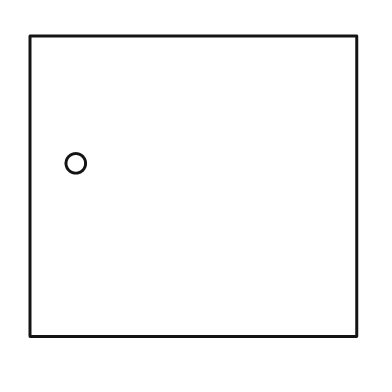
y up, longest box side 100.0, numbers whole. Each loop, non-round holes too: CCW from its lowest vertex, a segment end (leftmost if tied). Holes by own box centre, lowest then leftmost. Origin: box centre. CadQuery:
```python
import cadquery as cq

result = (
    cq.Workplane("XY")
    .moveTo(-50.0, -46.0)
    .lineTo(50.0, -46.0)
    .lineTo(50.0, 46.0)
    .lineTo(-50.0, 46.0)
    .close()
    .moveTo(-36.0, 7.0)
    .circle(3.0)
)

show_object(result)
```